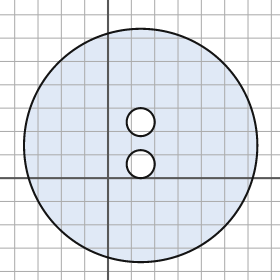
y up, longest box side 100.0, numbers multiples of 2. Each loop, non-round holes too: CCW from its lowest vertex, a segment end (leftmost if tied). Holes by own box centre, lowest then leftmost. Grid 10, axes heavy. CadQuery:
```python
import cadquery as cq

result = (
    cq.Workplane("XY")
    .moveTo(14.0, 14.0)
    .circle(50.0)
    .moveTo(14.0, 6.0)
    .circle(6.0)
    .moveTo(14.0, 24.0)
    .circle(6.0)
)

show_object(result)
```